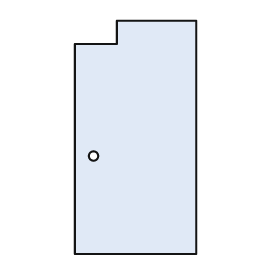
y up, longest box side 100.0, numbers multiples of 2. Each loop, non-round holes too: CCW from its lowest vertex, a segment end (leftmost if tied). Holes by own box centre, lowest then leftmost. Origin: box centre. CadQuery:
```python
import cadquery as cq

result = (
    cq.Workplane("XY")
    .moveTo(-26.0, -50.0)
    .lineTo(26.0, -50.0)
    .lineTo(26.0, 50.0)
    .lineTo(-8.0, 50.0)
    .lineTo(-8.0, 40.0)
    .lineTo(-26.0, 40.0)
    .close()
    .moveTo(-18.0, -8.0)
    .circle(2.0)
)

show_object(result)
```